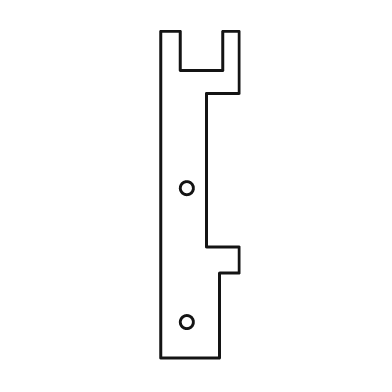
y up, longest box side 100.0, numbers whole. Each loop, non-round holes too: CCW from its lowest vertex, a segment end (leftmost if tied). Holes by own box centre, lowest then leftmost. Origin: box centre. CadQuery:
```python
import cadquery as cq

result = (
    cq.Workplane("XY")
    .moveTo(-12.0, -50.0)
    .lineTo(6.0, -50.0)
    .lineTo(6.0, -24.0)
    .lineTo(12.0, -24.0)
    .lineTo(12.0, -16.0)
    .lineTo(2.0, -16.0)
    .lineTo(2.0, 31.0)
    .lineTo(12.0, 31.0)
    .lineTo(12.0, 50.0)
    .lineTo(7.0, 50.0)
    .lineTo(7.0, 38.0)
    .lineTo(-6.0, 38.0)
    .lineTo(-6.0, 50.0)
    .lineTo(-12.0, 50.0)
    .close()
    .moveTo(-4.0, -39.0)
    .circle(2.0)
    .moveTo(-4.0, 2.0)
    .circle(2.0)
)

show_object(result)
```